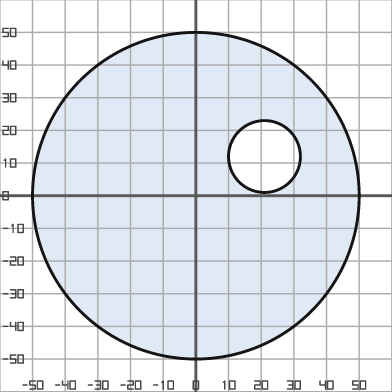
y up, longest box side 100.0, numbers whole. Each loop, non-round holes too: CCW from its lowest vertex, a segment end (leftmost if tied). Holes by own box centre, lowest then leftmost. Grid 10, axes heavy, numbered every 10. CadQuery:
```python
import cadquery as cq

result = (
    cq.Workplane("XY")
    .moveTo(0.0, 0.0)
    .circle(50.0)
    .moveTo(21.0, 12.0)
    .circle(11.0)
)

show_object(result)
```